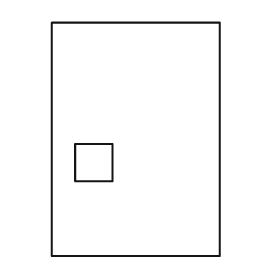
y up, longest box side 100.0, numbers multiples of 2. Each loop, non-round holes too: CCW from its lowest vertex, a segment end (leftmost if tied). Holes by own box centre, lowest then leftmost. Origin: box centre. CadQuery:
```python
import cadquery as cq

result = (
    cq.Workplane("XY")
    .moveTo(-36.0, -50.0)
    .lineTo(36.0, -50.0)
    .lineTo(36.0, 50.0)
    .lineTo(-36.0, 50.0)
    .close()
    .moveTo(-26.0, -18.0)
    .lineTo(-10.0, -18.0)
    .lineTo(-10.0, -2.0)
    .lineTo(-26.0, -2.0)
    .close()
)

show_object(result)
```